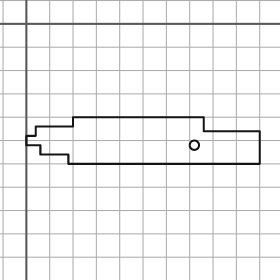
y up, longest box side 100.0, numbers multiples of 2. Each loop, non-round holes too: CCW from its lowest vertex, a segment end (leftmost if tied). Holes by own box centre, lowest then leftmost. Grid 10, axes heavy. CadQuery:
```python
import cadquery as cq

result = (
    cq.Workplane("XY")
    .moveTo(18.0, -60.0)
    .lineTo(100.0, -60.0)
    .lineTo(100.0, -46.0)
    .lineTo(76.0, -46.0)
    .lineTo(76.0, -40.0)
    .lineTo(20.0, -40.0)
    .lineTo(20.0, -44.0)
    .lineTo(4.0, -44.0)
    .lineTo(4.0, -48.0)
    .lineTo(0.0, -48.0)
    .lineTo(0.0, -52.0)
    .lineTo(6.0, -52.0)
    .lineTo(6.0, -56.0)
    .lineTo(18.0, -56.0)
    .close()
    .moveTo(72.0, -52.0)
    .circle(2.0)
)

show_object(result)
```